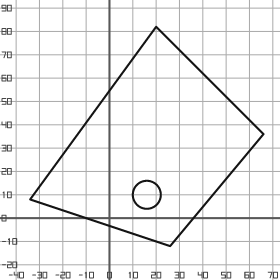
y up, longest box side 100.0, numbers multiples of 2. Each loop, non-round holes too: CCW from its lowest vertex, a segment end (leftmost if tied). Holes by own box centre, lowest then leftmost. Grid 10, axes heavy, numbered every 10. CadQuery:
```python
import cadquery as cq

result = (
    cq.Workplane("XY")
    .moveTo(26.0, -12.0)
    .lineTo(66.0, 36.0)
    .lineTo(20.0, 82.0)
    .lineTo(-34.0, 8.0)
    .close()
    .moveTo(16.0, 10.0)
    .circle(6.0)
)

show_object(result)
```